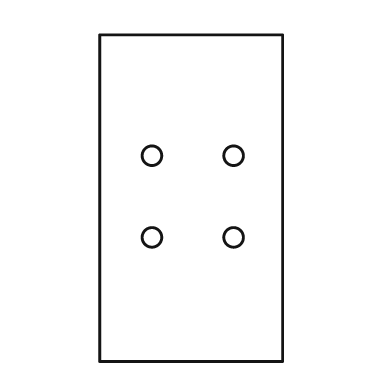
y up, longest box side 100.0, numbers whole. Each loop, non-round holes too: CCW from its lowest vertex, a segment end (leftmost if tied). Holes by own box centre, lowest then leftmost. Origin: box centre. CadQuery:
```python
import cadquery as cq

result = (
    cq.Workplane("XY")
    .moveTo(-28.0, -50.0)
    .lineTo(28.0, -50.0)
    .lineTo(28.0, 50.0)
    .lineTo(-28.0, 50.0)
    .close()
    .moveTo(-12.0, -12.0)
    .circle(3.0)
    .moveTo(13.0, -12.0)
    .circle(3.0)
    .moveTo(-12.0, 13.0)
    .circle(3.0)
    .moveTo(13.0, 13.0)
    .circle(3.0)
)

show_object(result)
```